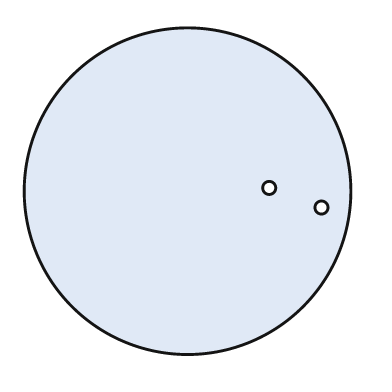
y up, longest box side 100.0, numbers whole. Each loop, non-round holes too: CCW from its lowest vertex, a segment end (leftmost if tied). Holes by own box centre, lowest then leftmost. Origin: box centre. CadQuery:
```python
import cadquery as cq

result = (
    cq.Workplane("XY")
    .moveTo(0.0, 0.0)
    .circle(50.0)
    .moveTo(41.0, -5.0)
    .circle(2.0)
    .moveTo(25.0, 1.0)
    .circle(2.0)
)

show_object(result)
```